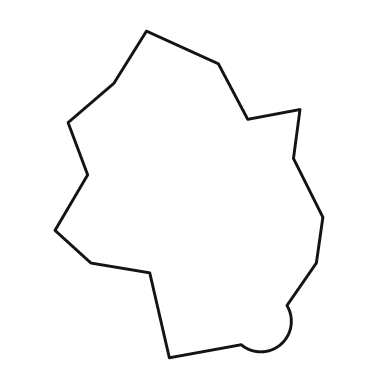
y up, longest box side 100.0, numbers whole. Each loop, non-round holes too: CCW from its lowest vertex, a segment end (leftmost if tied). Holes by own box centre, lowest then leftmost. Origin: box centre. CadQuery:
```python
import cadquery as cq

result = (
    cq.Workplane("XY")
    .moveTo(-6.0, -50.0)
    .lineTo(16.0, -46.0)
    .threePointArc((28.0, -46.0), (30.0, -34.0))
    .lineTo(39.0, -21.0)
    .lineTo(41.0, -7.0)
    .lineTo(32.0, 11.0)
    .lineTo(34.0, 26.0)
    .lineTo(18.0, 23.0)
    .lineTo(9.0, 40.0)
    .lineTo(-13.0, 50.0)
    .lineTo(-23.0, 34.0)
    .lineTo(-37.0, 22.0)
    .lineTo(-31.0, 6.0)
    .lineTo(-41.0, -11.0)
    .lineTo(-30.0, -21.0)
    .lineTo(-12.0, -24.0)
    .close()
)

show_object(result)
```